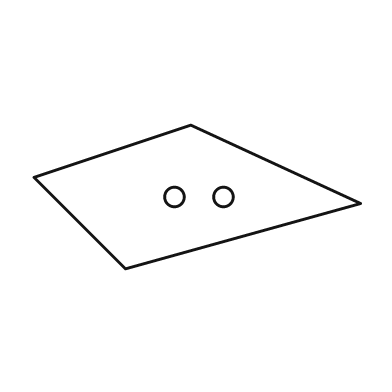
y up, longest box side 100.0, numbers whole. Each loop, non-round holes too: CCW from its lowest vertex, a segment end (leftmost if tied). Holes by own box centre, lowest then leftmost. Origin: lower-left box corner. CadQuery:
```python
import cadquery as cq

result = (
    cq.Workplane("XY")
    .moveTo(28.0, 0.0)
    .lineTo(100.0, 20.0)
    .lineTo(48.0, 44.0)
    .lineTo(0.0, 28.0)
    .close()
    .moveTo(43.0, 22.0)
    .circle(3.0)
    .moveTo(58.0, 22.0)
    .circle(3.0)
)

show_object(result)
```